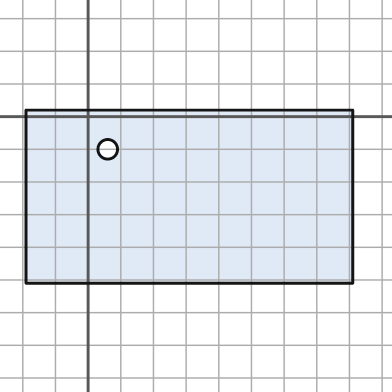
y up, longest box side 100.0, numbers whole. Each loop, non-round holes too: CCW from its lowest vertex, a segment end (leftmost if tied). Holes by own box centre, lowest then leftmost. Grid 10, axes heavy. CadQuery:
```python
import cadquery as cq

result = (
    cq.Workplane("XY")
    .moveTo(-19.0, -51.0)
    .lineTo(81.0, -51.0)
    .lineTo(81.0, 2.0)
    .lineTo(-19.0, 2.0)
    .close()
    .moveTo(6.0, -10.0)
    .circle(3.0)
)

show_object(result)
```